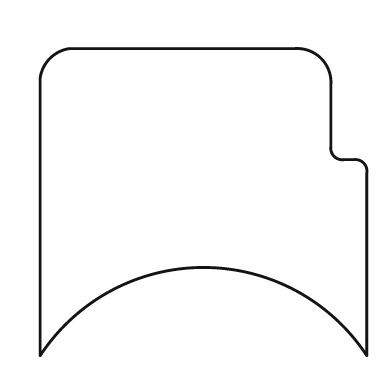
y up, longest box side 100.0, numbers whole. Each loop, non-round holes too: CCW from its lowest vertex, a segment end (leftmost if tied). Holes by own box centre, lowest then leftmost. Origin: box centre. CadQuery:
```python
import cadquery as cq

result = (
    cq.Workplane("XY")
    .moveTo(-50.0, -47.0)
    .threePointArc((0.0, -20.0), (50.0, -47.0))
    .lineTo(50.0, 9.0)
    .threePointArc((49.0, 12.0), (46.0, 13.0))
    .lineTo(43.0, 13.0)
    .threePointArc((40.0, 14.0), (39.0, 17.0))
    .lineTo(39.0, 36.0)
    .threePointArc((36.0, 44.0), (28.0, 47.0))
    .lineTo(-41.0, 47.0)
    .threePointArc((-47.0, 44.0), (-50.0, 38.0))
    .close()
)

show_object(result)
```